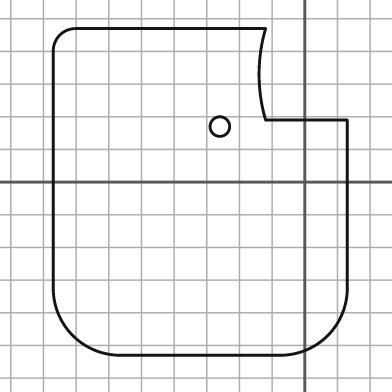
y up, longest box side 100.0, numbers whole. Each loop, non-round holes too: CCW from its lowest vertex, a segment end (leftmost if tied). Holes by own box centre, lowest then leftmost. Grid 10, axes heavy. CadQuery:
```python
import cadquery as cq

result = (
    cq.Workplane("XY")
    .moveTo(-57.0, -53.0)
    .lineTo(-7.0, -53.0)
    .threePointArc((7.0, -47.0), (13.0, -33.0))
    .lineTo(13.0, 19.0)
    .lineTo(-12.0, 19.0)
    .threePointArc((-14.0, 33.0), (-12.0, 47.0))
    .lineTo(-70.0, 47.0)
    .threePointArc((-75.0, 45.0), (-77.0, 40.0))
    .lineTo(-77.0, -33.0)
    .threePointArc((-71.0, -47.0), (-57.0, -53.0))
    .close()
    .moveTo(-26.0, 17.0)
    .circle(3.0)
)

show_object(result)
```